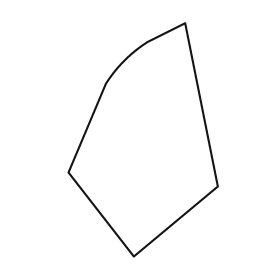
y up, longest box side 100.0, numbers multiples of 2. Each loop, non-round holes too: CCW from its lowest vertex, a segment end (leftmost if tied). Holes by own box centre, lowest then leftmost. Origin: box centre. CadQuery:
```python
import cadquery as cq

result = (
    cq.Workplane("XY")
    .moveTo(-4.0, -50.0)
    .lineTo(32.0, -20.0)
    .lineTo(18.0, 50.0)
    .lineTo(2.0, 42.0)
    .threePointArc((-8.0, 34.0), (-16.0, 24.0))
    .lineTo(-32.0, -14.0)
    .close()
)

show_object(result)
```